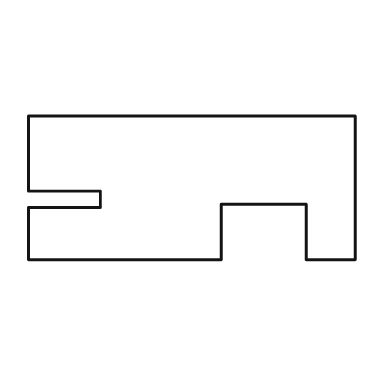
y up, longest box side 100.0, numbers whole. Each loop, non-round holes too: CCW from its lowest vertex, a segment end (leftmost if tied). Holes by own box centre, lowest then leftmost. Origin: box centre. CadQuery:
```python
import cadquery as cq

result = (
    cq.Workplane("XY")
    .moveTo(-50.0, -22.0)
    .lineTo(9.0, -22.0)
    .lineTo(9.0, -5.0)
    .lineTo(35.0, -5.0)
    .lineTo(35.0, -22.0)
    .lineTo(50.0, -22.0)
    .lineTo(50.0, 22.0)
    .lineTo(-50.0, 22.0)
    .lineTo(-50.0, -1.0)
    .lineTo(-28.0, -1.0)
    .lineTo(-28.0, -6.0)
    .lineTo(-50.0, -6.0)
    .close()
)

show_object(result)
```